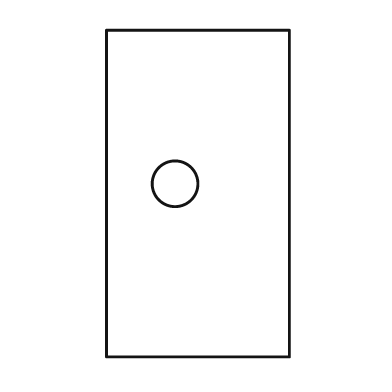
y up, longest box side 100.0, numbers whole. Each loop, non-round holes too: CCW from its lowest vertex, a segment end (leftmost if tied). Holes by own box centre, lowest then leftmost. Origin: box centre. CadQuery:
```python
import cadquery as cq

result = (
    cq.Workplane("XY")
    .moveTo(-28.0, -50.0)
    .lineTo(28.0, -50.0)
    .lineTo(28.0, 50.0)
    .lineTo(-28.0, 50.0)
    .close()
    .moveTo(-7.0, 3.0)
    .circle(7.0)
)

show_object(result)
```